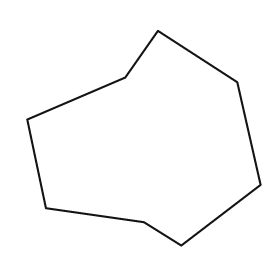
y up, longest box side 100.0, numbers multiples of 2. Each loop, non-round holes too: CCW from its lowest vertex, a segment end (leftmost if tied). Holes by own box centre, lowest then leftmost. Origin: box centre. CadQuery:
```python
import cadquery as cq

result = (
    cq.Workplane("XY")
    .moveTo(16.0, -46.0)
    .lineTo(50.0, -20.0)
    .lineTo(40.0, 24.0)
    .lineTo(6.0, 46.0)
    .lineTo(-8.0, 26.0)
    .lineTo(-50.0, 8.0)
    .lineTo(-42.0, -30.0)
    .lineTo(0.0, -36.0)
    .close()
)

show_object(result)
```